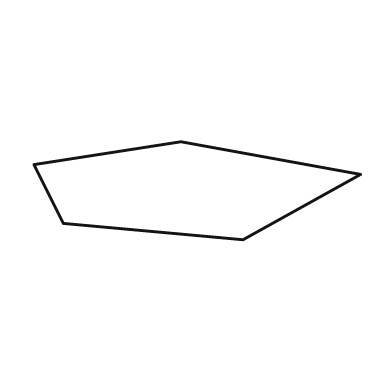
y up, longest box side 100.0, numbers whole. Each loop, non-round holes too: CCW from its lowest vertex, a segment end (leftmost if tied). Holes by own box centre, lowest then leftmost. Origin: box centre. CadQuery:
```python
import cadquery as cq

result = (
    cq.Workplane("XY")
    .moveTo(14.0, -15.0)
    .lineTo(50.0, 5.0)
    .lineTo(-5.0, 15.0)
    .lineTo(-50.0, 8.0)
    .lineTo(-41.0, -10.0)
    .close()
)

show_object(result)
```